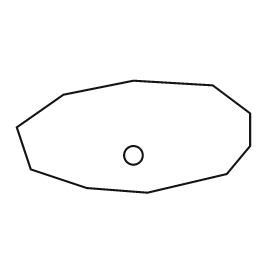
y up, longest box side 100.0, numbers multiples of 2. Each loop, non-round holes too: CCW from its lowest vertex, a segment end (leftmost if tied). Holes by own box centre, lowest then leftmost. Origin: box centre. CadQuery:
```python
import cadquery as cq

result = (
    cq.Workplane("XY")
    .moveTo(6.0, -24.0)
    .lineTo(40.0, -16.0)
    .lineTo(50.0, -4.0)
    .lineTo(50.0, 10.0)
    .lineTo(34.0, 22.0)
    .lineTo(0.0, 24.0)
    .lineTo(-30.0, 18.0)
    .lineTo(-50.0, 4.0)
    .lineTo(-44.0, -14.0)
    .lineTo(-20.0, -22.0)
    .close()
    .moveTo(0.0, -8.0)
    .circle(4.0)
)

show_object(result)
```